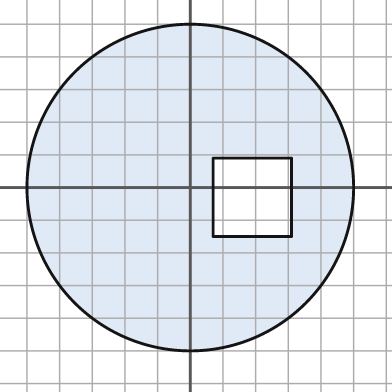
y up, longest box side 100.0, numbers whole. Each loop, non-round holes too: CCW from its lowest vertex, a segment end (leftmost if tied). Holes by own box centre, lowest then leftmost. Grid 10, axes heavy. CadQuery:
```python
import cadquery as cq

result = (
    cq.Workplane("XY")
    .moveTo(0.0, 0.0)
    .circle(50.0)
    .moveTo(7.0, -15.0)
    .lineTo(31.0, -15.0)
    .lineTo(31.0, 9.0)
    .lineTo(7.0, 9.0)
    .close()
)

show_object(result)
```